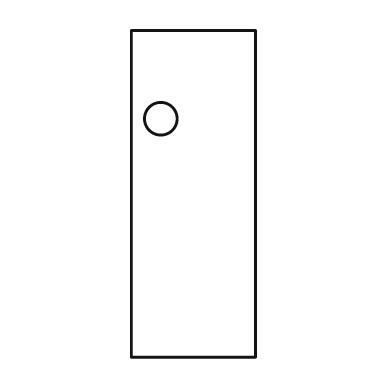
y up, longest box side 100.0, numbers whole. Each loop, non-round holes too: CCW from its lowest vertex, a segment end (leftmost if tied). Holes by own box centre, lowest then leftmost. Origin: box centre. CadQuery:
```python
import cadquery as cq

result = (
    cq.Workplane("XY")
    .moveTo(-19.0, -50.0)
    .lineTo(19.0, -50.0)
    .lineTo(19.0, 50.0)
    .lineTo(-19.0, 50.0)
    .close()
    .moveTo(-10.0, 23.0)
    .circle(5.0)
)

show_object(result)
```